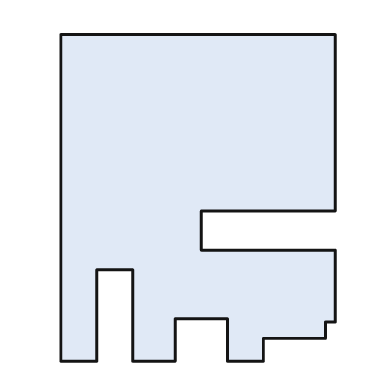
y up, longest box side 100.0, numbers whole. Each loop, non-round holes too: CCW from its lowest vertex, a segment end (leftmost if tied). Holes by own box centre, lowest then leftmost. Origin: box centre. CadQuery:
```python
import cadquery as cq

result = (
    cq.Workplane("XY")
    .moveTo(-42.0, -50.0)
    .lineTo(-31.0, -50.0)
    .lineTo(-31.0, -22.0)
    .lineTo(-20.0, -22.0)
    .lineTo(-20.0, -50.0)
    .lineTo(-7.0, -50.0)
    .lineTo(-7.0, -37.0)
    .lineTo(9.0, -37.0)
    .lineTo(9.0, -50.0)
    .lineTo(20.0, -50.0)
    .lineTo(20.0, -43.0)
    .lineTo(39.0, -43.0)
    .lineTo(39.0, -38.0)
    .lineTo(42.0, -38.0)
    .lineTo(42.0, -16.0)
    .lineTo(1.0, -16.0)
    .lineTo(1.0, -4.0)
    .lineTo(42.0, -4.0)
    .lineTo(42.0, 50.0)
    .lineTo(-42.0, 50.0)
    .close()
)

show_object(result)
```